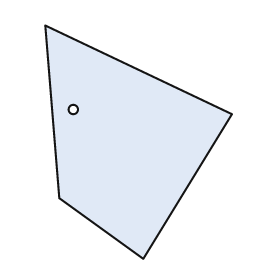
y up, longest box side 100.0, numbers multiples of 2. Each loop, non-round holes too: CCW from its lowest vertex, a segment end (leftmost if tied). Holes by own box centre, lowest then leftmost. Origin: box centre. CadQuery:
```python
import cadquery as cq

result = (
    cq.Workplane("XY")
    .moveTo(2.0, -50.0)
    .lineTo(40.0, 12.0)
    .lineTo(-40.0, 50.0)
    .lineTo(-34.0, -24.0)
    .close()
    .moveTo(-28.0, 14.0)
    .circle(2.0)
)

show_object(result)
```